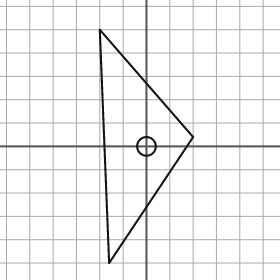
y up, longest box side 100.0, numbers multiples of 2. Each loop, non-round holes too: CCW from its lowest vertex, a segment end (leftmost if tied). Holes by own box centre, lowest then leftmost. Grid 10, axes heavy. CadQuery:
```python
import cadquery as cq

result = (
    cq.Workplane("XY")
    .moveTo(-16.0, -50.0)
    .lineTo(20.0, 4.0)
    .lineTo(-20.0, 50.0)
    .close()
    .moveTo(0.0, 0.0)
    .circle(4.0)
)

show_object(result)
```